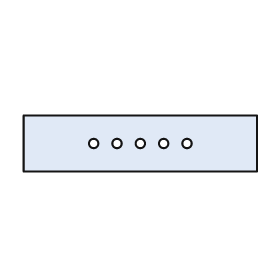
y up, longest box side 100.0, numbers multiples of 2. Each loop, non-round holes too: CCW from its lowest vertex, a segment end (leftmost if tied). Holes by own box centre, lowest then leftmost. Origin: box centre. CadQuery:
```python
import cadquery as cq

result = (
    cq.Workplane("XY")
    .moveTo(-50.0, -12.0)
    .lineTo(50.0, -12.0)
    .lineTo(50.0, 12.0)
    .lineTo(-50.0, 12.0)
    .close()
    .moveTo(-20.0, 0.0)
    .circle(2.0)
    .moveTo(-10.0, 0.0)
    .circle(2.0)
    .moveTo(0.0, 0.0)
    .circle(2.0)
    .moveTo(10.0, 0.0)
    .circle(2.0)
    .moveTo(20.0, 0.0)
    .circle(2.0)
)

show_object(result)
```